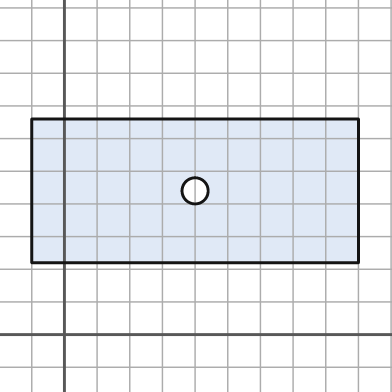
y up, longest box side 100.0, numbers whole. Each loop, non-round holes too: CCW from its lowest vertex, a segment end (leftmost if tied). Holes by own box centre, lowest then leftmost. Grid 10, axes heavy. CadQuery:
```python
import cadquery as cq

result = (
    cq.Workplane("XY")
    .moveTo(-10.0, 22.0)
    .lineTo(90.0, 22.0)
    .lineTo(90.0, 66.0)
    .lineTo(-10.0, 66.0)
    .close()
    .moveTo(40.0, 44.0)
    .circle(4.0)
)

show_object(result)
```